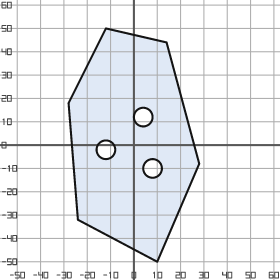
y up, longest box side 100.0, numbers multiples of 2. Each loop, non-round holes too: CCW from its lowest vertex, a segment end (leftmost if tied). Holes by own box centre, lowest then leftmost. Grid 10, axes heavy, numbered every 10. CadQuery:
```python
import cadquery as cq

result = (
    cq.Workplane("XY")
    .moveTo(10.0, -50.0)
    .lineTo(28.0, -8.0)
    .lineTo(14.0, 44.0)
    .lineTo(-12.0, 50.0)
    .lineTo(-28.0, 18.0)
    .lineTo(-24.0, -32.0)
    .close()
    .moveTo(8.0, -10.0)
    .circle(4.0)
    .moveTo(-12.0, -2.0)
    .circle(4.0)
    .moveTo(4.0, 12.0)
    .circle(4.0)
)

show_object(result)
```